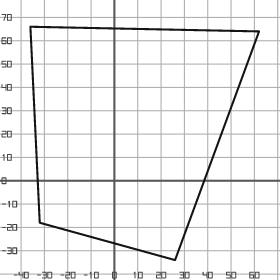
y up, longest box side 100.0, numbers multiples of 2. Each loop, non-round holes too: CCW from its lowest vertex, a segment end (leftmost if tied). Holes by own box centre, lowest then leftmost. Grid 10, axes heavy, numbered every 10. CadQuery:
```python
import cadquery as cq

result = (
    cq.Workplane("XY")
    .moveTo(26.0, -34.0)
    .lineTo(62.0, 64.0)
    .lineTo(-36.0, 66.0)
    .lineTo(-32.0, -18.0)
    .close()
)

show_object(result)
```